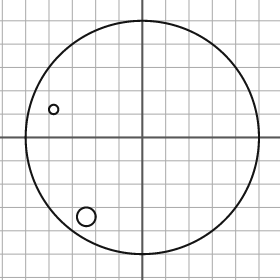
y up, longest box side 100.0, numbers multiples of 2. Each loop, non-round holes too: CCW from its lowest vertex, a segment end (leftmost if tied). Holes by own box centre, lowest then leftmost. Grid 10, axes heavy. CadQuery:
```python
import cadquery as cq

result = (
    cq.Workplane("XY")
    .moveTo(0.0, 0.0)
    .circle(50.0)
    .moveTo(-24.0, -34.0)
    .circle(4.0)
    .moveTo(-38.0, 12.0)
    .circle(2.0)
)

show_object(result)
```